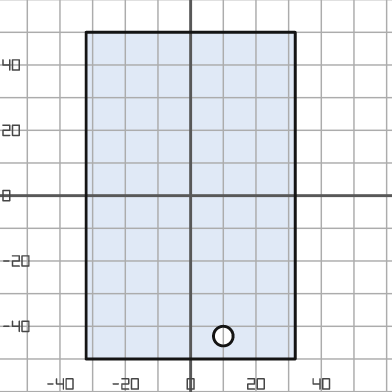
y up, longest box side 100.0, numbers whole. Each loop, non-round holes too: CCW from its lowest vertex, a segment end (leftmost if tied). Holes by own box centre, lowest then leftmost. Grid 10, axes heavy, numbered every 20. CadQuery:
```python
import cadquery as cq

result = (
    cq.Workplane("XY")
    .moveTo(-32.0, -50.0)
    .lineTo(32.0, -50.0)
    .lineTo(32.0, 50.0)
    .lineTo(-32.0, 50.0)
    .close()
    .moveTo(10.0, -43.0)
    .circle(3.0)
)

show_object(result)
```